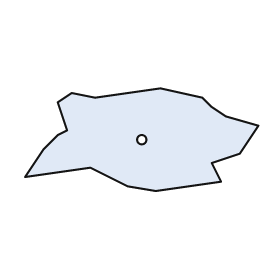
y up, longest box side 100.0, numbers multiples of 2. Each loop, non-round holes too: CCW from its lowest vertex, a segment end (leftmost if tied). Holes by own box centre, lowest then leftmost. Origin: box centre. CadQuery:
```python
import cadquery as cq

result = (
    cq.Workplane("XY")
    .moveTo(6.0, -22.0)
    .lineTo(34.0, -18.0)
    .lineTo(30.0, -10.0)
    .lineTo(42.0, -6.0)
    .lineTo(50.0, 6.0)
    .lineTo(36.0, 10.0)
    .lineTo(30.0, 14.0)
    .lineTo(26.0, 18.0)
    .lineTo(8.0, 22.0)
    .lineTo(-20.0, 18.0)
    .lineTo(-30.0, 20.0)
    .lineTo(-36.0, 16.0)
    .lineTo(-32.0, 4.0)
    .lineTo(-36.0, 2.0)
    .lineTo(-42.0, -4.0)
    .lineTo(-50.0, -16.0)
    .lineTo(-22.0, -12.0)
    .lineTo(-6.0, -20.0)
    .close()
    .moveTo(0.0, 0.0)
    .circle(2.0)
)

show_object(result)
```